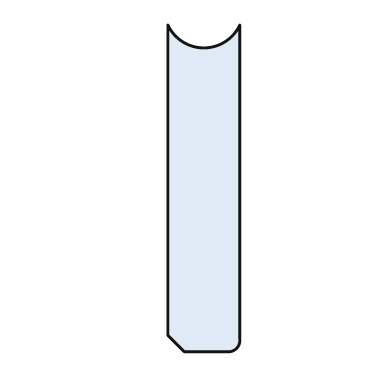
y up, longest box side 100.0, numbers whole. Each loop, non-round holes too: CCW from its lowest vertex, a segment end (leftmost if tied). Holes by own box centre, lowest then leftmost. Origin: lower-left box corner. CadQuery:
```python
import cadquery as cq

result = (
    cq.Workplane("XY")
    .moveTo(5.0, 0.0)
    .lineTo(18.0, 0.0)
    .threePointArc((21.0, 1.0), (22.0, 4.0))
    .lineTo(22.0, 100.0)
    .threePointArc((11.0, 93.0), (0.0, 100.0))
    .lineTo(0.0, 5.0)
    .close()
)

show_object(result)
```